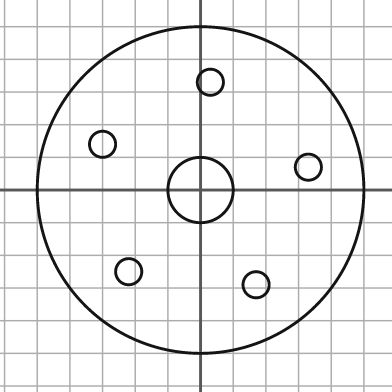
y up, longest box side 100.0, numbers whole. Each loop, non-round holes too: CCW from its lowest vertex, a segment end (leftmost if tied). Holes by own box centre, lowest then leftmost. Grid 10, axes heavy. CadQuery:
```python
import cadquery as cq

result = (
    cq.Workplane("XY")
    .moveTo(0.0, 0.0)
    .circle(50.0)
    .moveTo(17.0, -29.0)
    .circle(4.0)
    .moveTo(-22.0, -25.0)
    .circle(4.0)
    .moveTo(0.0, 0.0)
    .circle(10.0)
    .moveTo(33.0, 7.0)
    .circle(4.0)
    .moveTo(-30.0, 14.0)
    .circle(4.0)
    .moveTo(3.0, 33.0)
    .circle(4.0)
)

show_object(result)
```